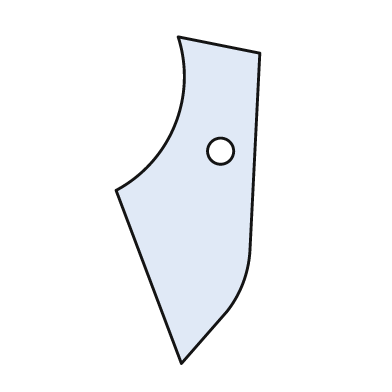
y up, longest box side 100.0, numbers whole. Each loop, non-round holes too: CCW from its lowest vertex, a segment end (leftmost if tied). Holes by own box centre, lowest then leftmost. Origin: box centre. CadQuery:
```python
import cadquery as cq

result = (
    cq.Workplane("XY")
    .moveTo(-2.0, -50.0)
    .lineTo(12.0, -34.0)
    .threePointArc((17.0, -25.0), (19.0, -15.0))
    .lineTo(22.0, 45.0)
    .lineTo(-3.0, 50.0)
    .threePointArc((-4.0, 23.0), (-22.0, 3.0))
    .close()
    .moveTo(10.0, 15.0)
    .circle(4.0)
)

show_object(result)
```